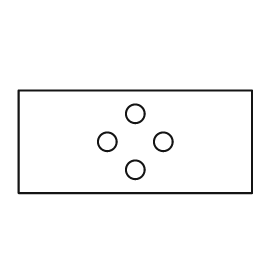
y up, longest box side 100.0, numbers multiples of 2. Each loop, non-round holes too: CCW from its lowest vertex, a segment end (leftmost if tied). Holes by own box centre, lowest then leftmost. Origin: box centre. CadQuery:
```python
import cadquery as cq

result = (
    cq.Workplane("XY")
    .moveTo(-50.0, -22.0)
    .lineTo(50.0, -22.0)
    .lineTo(50.0, 22.0)
    .lineTo(-50.0, 22.0)
    .close()
    .moveTo(0.0, -12.0)
    .circle(4.0)
    .moveTo(-12.0, 0.0)
    .circle(4.0)
    .moveTo(12.0, 0.0)
    .circle(4.0)
    .moveTo(0.0, 12.0)
    .circle(4.0)
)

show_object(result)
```